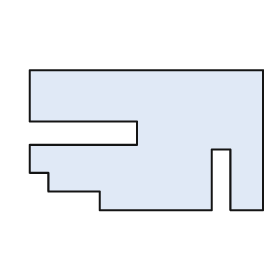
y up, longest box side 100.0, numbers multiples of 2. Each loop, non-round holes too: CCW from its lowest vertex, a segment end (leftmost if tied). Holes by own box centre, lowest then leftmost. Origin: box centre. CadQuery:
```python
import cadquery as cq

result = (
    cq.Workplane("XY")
    .moveTo(-20.0, -30.0)
    .lineTo(28.0, -30.0)
    .lineTo(28.0, -4.0)
    .lineTo(36.0, -4.0)
    .lineTo(36.0, -30.0)
    .lineTo(50.0, -30.0)
    .lineTo(50.0, 30.0)
    .lineTo(-50.0, 30.0)
    .lineTo(-50.0, 8.0)
    .lineTo(-4.0, 8.0)
    .lineTo(-4.0, -2.0)
    .lineTo(-50.0, -2.0)
    .lineTo(-50.0, -14.0)
    .lineTo(-42.0, -14.0)
    .lineTo(-42.0, -22.0)
    .lineTo(-20.0, -22.0)
    .close()
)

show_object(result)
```